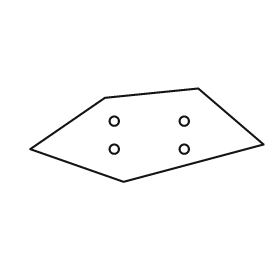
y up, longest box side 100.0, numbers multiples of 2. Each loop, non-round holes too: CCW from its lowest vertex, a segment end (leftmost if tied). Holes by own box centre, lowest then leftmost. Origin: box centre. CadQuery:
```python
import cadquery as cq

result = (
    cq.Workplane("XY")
    .moveTo(-10.0, -20.0)
    .lineTo(50.0, -4.0)
    .lineTo(22.0, 20.0)
    .lineTo(-18.0, 16.0)
    .lineTo(-50.0, -6.0)
    .close()
    .moveTo(-14.0, -6.0)
    .circle(2.0)
    .moveTo(16.0, -6.0)
    .circle(2.0)
    .moveTo(-14.0, 6.0)
    .circle(2.0)
    .moveTo(16.0, 6.0)
    .circle(2.0)
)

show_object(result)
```